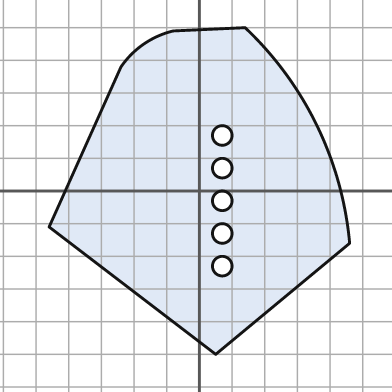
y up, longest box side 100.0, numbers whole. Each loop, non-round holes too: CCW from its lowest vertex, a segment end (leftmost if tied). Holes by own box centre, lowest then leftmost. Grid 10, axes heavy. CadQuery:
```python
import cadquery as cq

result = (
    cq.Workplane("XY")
    .moveTo(5.0, -50.0)
    .lineTo(46.0, -16.0)
    .threePointArc((36.0, 20.0), (14.0, 50.0))
    .lineTo(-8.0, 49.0)
    .threePointArc((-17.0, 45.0), (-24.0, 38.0))
    .lineTo(-46.0, -11.0)
    .close()
    .moveTo(7.0, -23.0)
    .circle(3.0)
    .moveTo(7.0, -13.0)
    .circle(3.0)
    .moveTo(7.0, -3.0)
    .circle(3.0)
    .moveTo(7.0, 7.0)
    .circle(3.0)
    .moveTo(7.0, 17.0)
    .circle(3.0)
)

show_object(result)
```